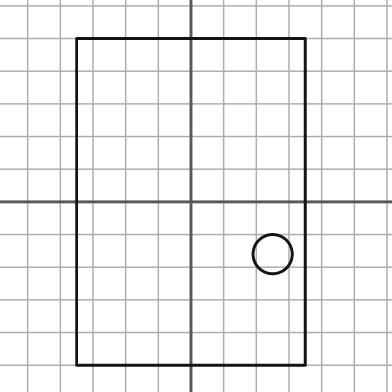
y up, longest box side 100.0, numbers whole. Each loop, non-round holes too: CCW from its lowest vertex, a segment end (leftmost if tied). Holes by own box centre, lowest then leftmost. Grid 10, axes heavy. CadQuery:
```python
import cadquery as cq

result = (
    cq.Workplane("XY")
    .moveTo(-35.0, -50.0)
    .lineTo(35.0, -50.0)
    .lineTo(35.0, 50.0)
    .lineTo(-35.0, 50.0)
    .close()
    .moveTo(25.0, -16.0)
    .circle(6.0)
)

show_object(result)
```